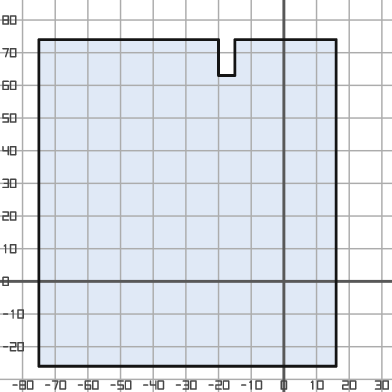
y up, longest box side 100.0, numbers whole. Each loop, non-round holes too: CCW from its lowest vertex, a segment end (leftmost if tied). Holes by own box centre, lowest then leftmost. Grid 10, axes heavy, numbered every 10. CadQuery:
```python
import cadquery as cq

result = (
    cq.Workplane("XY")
    .moveTo(-75.0, -26.0)
    .lineTo(16.0, -26.0)
    .lineTo(16.0, 74.0)
    .lineTo(-15.0, 74.0)
    .lineTo(-15.0, 63.0)
    .lineTo(-20.0, 63.0)
    .lineTo(-20.0, 74.0)
    .lineTo(-75.0, 74.0)
    .close()
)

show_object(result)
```